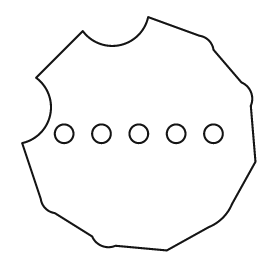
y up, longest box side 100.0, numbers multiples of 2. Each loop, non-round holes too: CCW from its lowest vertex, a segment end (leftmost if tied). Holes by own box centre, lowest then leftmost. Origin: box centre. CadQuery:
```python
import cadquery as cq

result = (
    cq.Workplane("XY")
    .moveTo(12.0, -50.0)
    .lineTo(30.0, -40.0)
    .threePointArc((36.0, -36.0), (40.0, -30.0))
    .lineTo(50.0, -12.0)
    .lineTo(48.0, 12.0)
    .threePointArc((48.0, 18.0), (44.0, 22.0))
    .lineTo(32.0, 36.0)
    .threePointArc((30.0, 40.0), (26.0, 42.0))
    .lineTo(4.0, 50.0)
    .threePointArc((-8.0, 38.0), (-24.0, 44.0))
    .lineTo(-44.0, 24.0)
    .threePointArc((-38.0, 8.0), (-50.0, -4.0))
    .lineTo(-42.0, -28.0)
    .threePointArc((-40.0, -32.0), (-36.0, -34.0))
    .lineTo(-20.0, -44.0)
    .threePointArc((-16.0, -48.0), (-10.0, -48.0))
    .close()
    .moveTo(-32.0, 0.0)
    .circle(4.0)
    .moveTo(-16.0, 0.0)
    .circle(4.0)
    .moveTo(0.0, 0.0)
    .circle(4.0)
    .moveTo(16.0, 0.0)
    .circle(4.0)
    .moveTo(32.0, 0.0)
    .circle(4.0)
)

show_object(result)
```